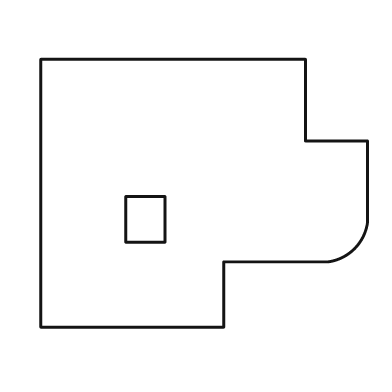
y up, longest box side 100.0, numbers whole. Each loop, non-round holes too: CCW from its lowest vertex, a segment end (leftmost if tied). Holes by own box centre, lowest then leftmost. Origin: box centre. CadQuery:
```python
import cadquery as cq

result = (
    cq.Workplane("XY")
    .moveTo(-50.0, -41.0)
    .lineTo(6.0, -41.0)
    .lineTo(6.0, -21.0)
    .lineTo(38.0, -21.0)
    .threePointArc((46.0, -17.0), (50.0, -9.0))
    .lineTo(50.0, 16.0)
    .lineTo(31.0, 16.0)
    .lineTo(31.0, 41.0)
    .lineTo(-50.0, 41.0)
    .close()
    .moveTo(-24.0, -15.0)
    .lineTo(-12.0, -15.0)
    .lineTo(-12.0, -1.0)
    .lineTo(-24.0, -1.0)
    .close()
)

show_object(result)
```